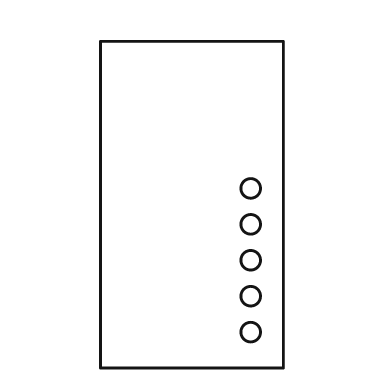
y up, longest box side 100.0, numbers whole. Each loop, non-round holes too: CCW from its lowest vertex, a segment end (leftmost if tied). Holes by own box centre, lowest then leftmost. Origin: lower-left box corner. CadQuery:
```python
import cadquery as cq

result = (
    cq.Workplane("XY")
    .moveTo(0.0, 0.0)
    .lineTo(56.0, 0.0)
    .lineTo(56.0, 100.0)
    .lineTo(0.0, 100.0)
    .close()
    .moveTo(46.0, 11.0)
    .circle(3.0)
    .moveTo(46.0, 22.0)
    .circle(3.0)
    .moveTo(46.0, 33.0)
    .circle(3.0)
    .moveTo(46.0, 44.0)
    .circle(3.0)
    .moveTo(46.0, 55.0)
    .circle(3.0)
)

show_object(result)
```